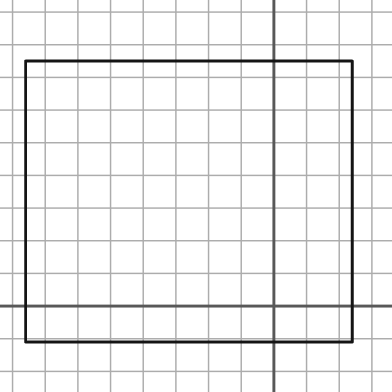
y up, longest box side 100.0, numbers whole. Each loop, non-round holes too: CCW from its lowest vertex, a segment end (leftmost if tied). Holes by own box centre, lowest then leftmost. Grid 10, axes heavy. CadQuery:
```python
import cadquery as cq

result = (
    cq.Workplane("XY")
    .moveTo(-76.0, -11.0)
    .lineTo(24.0, -11.0)
    .lineTo(24.0, 75.0)
    .lineTo(-76.0, 75.0)
    .close()
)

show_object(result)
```